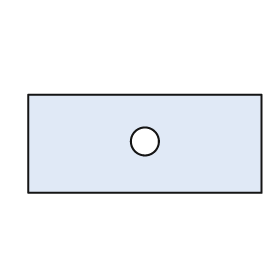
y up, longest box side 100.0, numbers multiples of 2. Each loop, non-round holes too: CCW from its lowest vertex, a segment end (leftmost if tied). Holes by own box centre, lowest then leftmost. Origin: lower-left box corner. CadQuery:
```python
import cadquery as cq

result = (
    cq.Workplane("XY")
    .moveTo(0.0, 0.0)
    .lineTo(100.0, 0.0)
    .lineTo(100.0, 42.0)
    .lineTo(0.0, 42.0)
    .close()
    .moveTo(50.0, 22.0)
    .circle(6.0)
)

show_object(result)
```